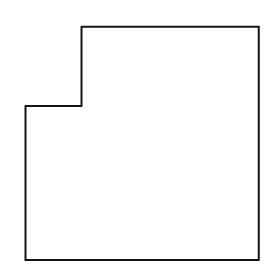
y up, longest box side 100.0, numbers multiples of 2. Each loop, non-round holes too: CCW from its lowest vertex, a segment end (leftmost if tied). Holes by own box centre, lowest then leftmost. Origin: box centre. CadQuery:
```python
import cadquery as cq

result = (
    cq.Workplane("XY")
    .moveTo(-50.0, -50.0)
    .lineTo(50.0, -50.0)
    .lineTo(50.0, 50.0)
    .lineTo(-26.0, 50.0)
    .lineTo(-26.0, 16.0)
    .lineTo(-50.0, 16.0)
    .close()
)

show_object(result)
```